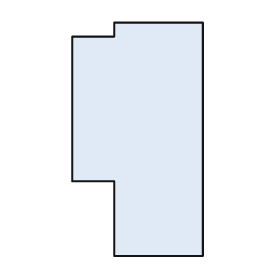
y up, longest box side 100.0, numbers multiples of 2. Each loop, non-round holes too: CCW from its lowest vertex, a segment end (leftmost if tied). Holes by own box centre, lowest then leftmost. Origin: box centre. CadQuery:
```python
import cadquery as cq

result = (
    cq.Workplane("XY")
    .moveTo(-10.0, -50.0)
    .lineTo(28.0, -50.0)
    .lineTo(28.0, 50.0)
    .lineTo(-10.0, 50.0)
    .lineTo(-10.0, 44.0)
    .lineTo(-28.0, 44.0)
    .lineTo(-28.0, -18.0)
    .lineTo(-10.0, -18.0)
    .close()
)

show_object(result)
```